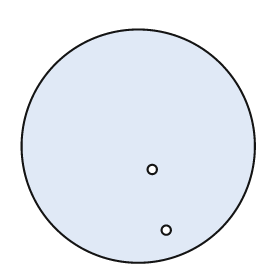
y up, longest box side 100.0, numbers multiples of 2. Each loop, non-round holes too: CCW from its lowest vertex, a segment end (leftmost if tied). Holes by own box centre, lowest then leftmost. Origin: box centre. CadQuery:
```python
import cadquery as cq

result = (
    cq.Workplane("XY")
    .moveTo(0.0, 0.0)
    .circle(50.0)
    .moveTo(12.0, -36.0)
    .circle(2.0)
    .moveTo(6.0, -10.0)
    .circle(2.0)
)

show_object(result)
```